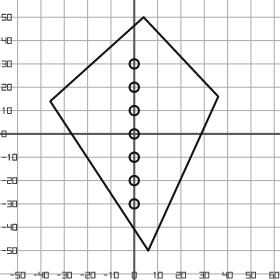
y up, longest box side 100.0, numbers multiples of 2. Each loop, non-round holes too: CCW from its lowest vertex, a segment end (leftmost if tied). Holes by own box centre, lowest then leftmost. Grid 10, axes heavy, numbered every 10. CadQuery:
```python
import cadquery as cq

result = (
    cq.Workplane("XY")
    .moveTo(6.0, -50.0)
    .lineTo(36.0, 16.0)
    .lineTo(4.0, 50.0)
    .lineTo(-36.0, 14.0)
    .close()
    .moveTo(0.0, -30.0)
    .circle(2.0)
    .moveTo(0.0, -20.0)
    .circle(2.0)
    .moveTo(0.0, -10.0)
    .circle(2.0)
    .moveTo(0.0, 0.0)
    .circle(2.0)
    .moveTo(0.0, 10.0)
    .circle(2.0)
    .moveTo(0.0, 20.0)
    .circle(2.0)
    .moveTo(0.0, 30.0)
    .circle(2.0)
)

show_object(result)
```